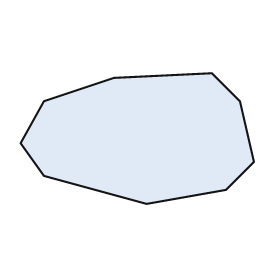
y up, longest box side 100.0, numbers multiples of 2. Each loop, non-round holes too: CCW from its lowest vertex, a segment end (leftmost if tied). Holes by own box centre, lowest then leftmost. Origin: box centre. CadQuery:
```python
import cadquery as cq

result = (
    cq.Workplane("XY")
    .moveTo(4.0, -28.0)
    .lineTo(38.0, -22.0)
    .lineTo(50.0, -10.0)
    .lineTo(44.0, 16.0)
    .lineTo(32.0, 28.0)
    .lineTo(-10.0, 26.0)
    .lineTo(-40.0, 16.0)
    .lineTo(-50.0, -2.0)
    .lineTo(-40.0, -16.0)
    .close()
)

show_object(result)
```